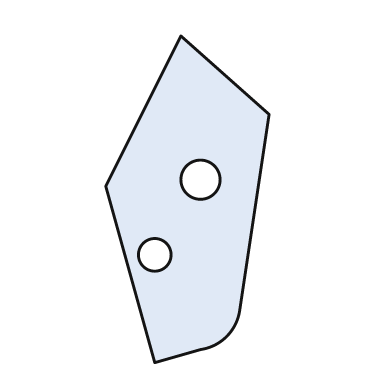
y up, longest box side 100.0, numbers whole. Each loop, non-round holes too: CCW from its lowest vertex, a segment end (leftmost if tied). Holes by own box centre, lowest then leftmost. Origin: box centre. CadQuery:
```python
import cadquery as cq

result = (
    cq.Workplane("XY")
    .moveTo(-10.0, -50.0)
    .lineTo(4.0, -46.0)
    .threePointArc((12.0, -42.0), (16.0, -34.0))
    .lineTo(25.0, 26.0)
    .lineTo(-2.0, 50.0)
    .lineTo(-25.0, 4.0)
    .close()
    .moveTo(-10.0, -17.0)
    .circle(5.0)
    .moveTo(4.0, 6.0)
    .circle(6.0)
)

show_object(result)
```